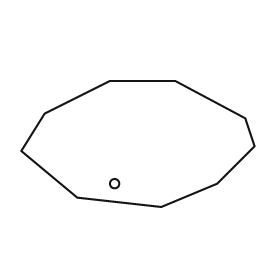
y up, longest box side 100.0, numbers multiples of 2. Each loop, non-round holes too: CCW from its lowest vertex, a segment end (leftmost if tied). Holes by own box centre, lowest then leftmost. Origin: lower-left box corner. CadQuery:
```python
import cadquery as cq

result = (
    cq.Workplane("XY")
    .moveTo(60.0, 0.0)
    .lineTo(84.0, 10.0)
    .lineTo(100.0, 26.0)
    .lineTo(96.0, 38.0)
    .lineTo(66.0, 54.0)
    .lineTo(38.0, 54.0)
    .lineTo(10.0, 40.0)
    .lineTo(0.0, 24.0)
    .lineTo(24.0, 4.0)
    .close()
    .moveTo(40.0, 10.0)
    .circle(2.0)
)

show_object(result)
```